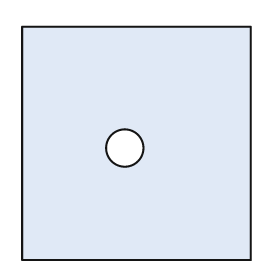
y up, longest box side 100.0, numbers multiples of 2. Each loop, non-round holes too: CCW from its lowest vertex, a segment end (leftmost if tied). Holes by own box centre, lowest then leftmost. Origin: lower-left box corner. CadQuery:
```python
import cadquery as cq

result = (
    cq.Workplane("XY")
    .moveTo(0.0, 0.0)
    .lineTo(98.0, 0.0)
    .lineTo(98.0, 100.0)
    .lineTo(0.0, 100.0)
    .close()
    .moveTo(44.0, 48.0)
    .circle(8.0)
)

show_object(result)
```